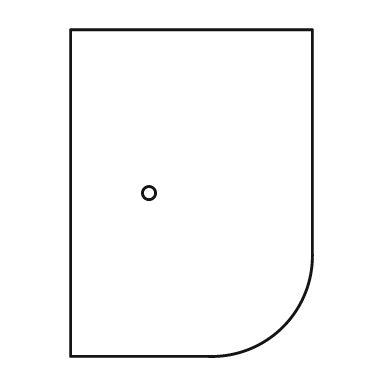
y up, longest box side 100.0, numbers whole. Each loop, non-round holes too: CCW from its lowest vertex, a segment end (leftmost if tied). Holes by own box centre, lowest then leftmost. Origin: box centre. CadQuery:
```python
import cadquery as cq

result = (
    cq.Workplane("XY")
    .moveTo(-37.0, -50.0)
    .lineTo(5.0, -50.0)
    .threePointArc((28.0, -41.0), (37.0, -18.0))
    .lineTo(37.0, 50.0)
    .lineTo(-37.0, 50.0)
    .close()
    .moveTo(-13.0, 0.0)
    .circle(2.0)
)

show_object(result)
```